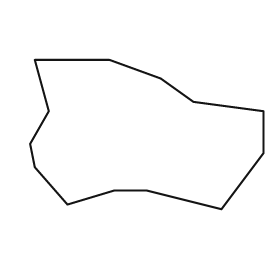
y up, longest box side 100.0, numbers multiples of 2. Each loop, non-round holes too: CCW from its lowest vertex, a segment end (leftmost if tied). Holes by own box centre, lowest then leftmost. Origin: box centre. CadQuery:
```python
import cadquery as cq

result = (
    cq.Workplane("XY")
    .moveTo(32.0, -32.0)
    .lineTo(50.0, -8.0)
    .lineTo(50.0, 10.0)
    .lineTo(20.0, 14.0)
    .lineTo(6.0, 24.0)
    .lineTo(-16.0, 32.0)
    .lineTo(-48.0, 32.0)
    .lineTo(-42.0, 10.0)
    .lineTo(-50.0, -4.0)
    .lineTo(-48.0, -14.0)
    .lineTo(-34.0, -30.0)
    .lineTo(-14.0, -24.0)
    .lineTo(0.0, -24.0)
    .close()
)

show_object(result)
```